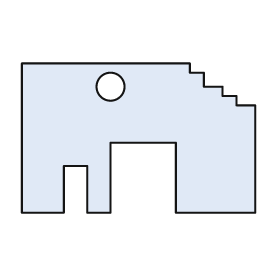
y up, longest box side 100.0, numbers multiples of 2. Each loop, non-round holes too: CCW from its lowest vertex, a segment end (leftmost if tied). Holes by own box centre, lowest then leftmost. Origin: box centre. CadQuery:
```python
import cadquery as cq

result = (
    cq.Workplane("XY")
    .moveTo(-50.0, -32.0)
    .lineTo(-32.0, -32.0)
    .lineTo(-32.0, -12.0)
    .lineTo(-22.0, -12.0)
    .lineTo(-22.0, -32.0)
    .lineTo(-12.0, -32.0)
    .lineTo(-12.0, -2.0)
    .lineTo(16.0, -2.0)
    .lineTo(16.0, -32.0)
    .lineTo(50.0, -32.0)
    .lineTo(50.0, 14.0)
    .lineTo(42.0, 14.0)
    .lineTo(42.0, 18.0)
    .lineTo(36.0, 18.0)
    .lineTo(36.0, 22.0)
    .lineTo(28.0, 22.0)
    .lineTo(28.0, 28.0)
    .lineTo(22.0, 28.0)
    .lineTo(22.0, 32.0)
    .lineTo(-50.0, 32.0)
    .close()
    .moveTo(-12.0, 22.0)
    .circle(6.0)
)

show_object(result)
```